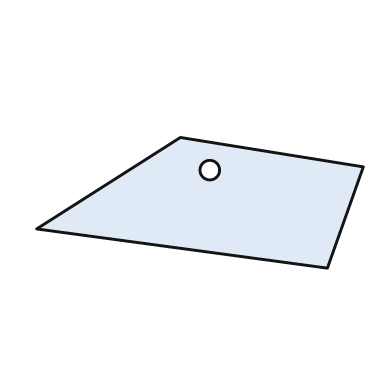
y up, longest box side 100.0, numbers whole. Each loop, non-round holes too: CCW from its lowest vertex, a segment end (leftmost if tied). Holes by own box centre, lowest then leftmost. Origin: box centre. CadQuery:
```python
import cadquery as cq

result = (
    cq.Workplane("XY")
    .moveTo(39.0, -20.0)
    .lineTo(50.0, 11.0)
    .lineTo(-6.0, 20.0)
    .lineTo(-50.0, -8.0)
    .close()
    .moveTo(3.0, 10.0)
    .circle(3.0)
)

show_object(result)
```